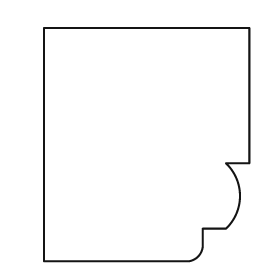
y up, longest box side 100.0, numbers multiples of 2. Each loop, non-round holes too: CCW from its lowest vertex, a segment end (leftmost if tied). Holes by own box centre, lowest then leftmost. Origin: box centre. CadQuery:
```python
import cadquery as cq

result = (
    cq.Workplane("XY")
    .moveTo(-44.0, -50.0)
    .lineTo(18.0, -50.0)
    .threePointArc((22.0, -48.0), (24.0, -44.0))
    .lineTo(24.0, -36.0)
    .lineTo(34.0, -36.0)
    .threePointArc((40.0, -22.0), (34.0, -8.0))
    .lineTo(44.0, -8.0)
    .lineTo(44.0, 50.0)
    .lineTo(-44.0, 50.0)
    .close()
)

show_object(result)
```